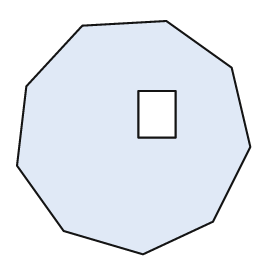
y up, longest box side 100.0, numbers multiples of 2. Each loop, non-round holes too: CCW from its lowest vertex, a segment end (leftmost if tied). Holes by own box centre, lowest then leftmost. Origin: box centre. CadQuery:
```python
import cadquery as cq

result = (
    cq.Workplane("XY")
    .moveTo(4.0, -50.0)
    .lineTo(34.0, -36.0)
    .lineTo(50.0, -4.0)
    .lineTo(42.0, 30.0)
    .lineTo(14.0, 50.0)
    .lineTo(-22.0, 48.0)
    .lineTo(-46.0, 22.0)
    .lineTo(-50.0, -12.0)
    .lineTo(-30.0, -40.0)
    .close()
    .moveTo(2.0, 0.0)
    .lineTo(18.0, 0.0)
    .lineTo(18.0, 20.0)
    .lineTo(2.0, 20.0)
    .close()
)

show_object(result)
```